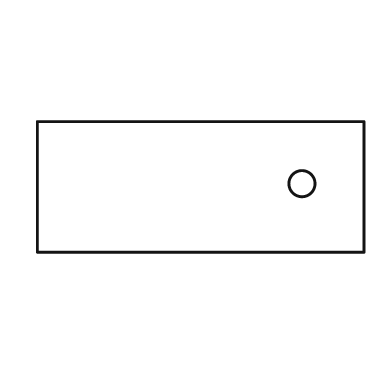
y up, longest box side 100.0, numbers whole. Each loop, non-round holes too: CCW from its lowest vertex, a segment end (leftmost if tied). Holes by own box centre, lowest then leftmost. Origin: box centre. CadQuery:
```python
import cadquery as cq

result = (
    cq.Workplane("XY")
    .moveTo(-50.0, -20.0)
    .lineTo(50.0, -20.0)
    .lineTo(50.0, 20.0)
    .lineTo(-50.0, 20.0)
    .close()
    .moveTo(31.0, 1.0)
    .circle(4.0)
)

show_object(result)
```